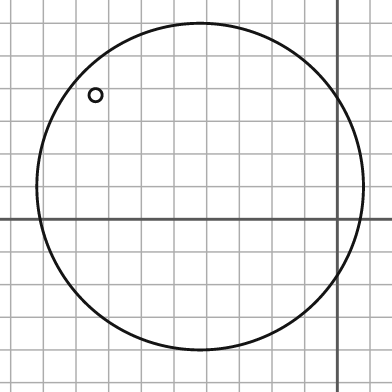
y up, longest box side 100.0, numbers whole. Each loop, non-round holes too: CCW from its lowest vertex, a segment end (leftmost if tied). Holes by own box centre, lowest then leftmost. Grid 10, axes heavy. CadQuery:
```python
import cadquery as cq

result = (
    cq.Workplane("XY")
    .moveTo(-42.0, 10.0)
    .circle(50.0)
    .moveTo(-74.0, 38.0)
    .circle(2.0)
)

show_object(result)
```